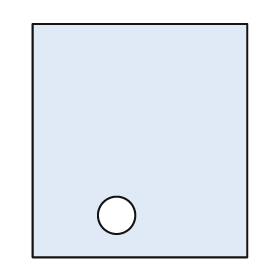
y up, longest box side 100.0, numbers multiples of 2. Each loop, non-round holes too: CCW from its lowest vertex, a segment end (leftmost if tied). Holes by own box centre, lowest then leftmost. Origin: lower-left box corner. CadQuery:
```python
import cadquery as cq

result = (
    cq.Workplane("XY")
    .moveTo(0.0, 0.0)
    .lineTo(92.0, 0.0)
    .lineTo(92.0, 100.0)
    .lineTo(0.0, 100.0)
    .close()
    .moveTo(36.0, 18.0)
    .circle(8.0)
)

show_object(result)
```